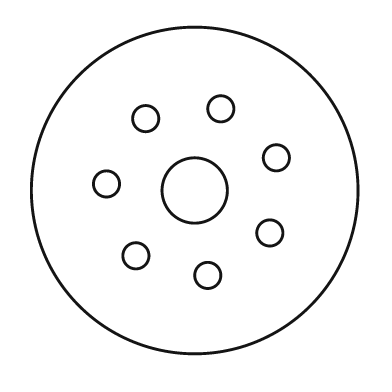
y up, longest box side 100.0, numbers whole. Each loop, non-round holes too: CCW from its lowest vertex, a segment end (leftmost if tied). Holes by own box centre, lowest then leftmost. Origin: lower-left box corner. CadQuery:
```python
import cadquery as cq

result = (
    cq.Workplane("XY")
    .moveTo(50.0, 50.0)
    .circle(50.0)
    .moveTo(54.0, 24.0)
    .circle(4.0)
    .moveTo(32.0, 30.0)
    .circle(4.0)
    .moveTo(73.0, 37.0)
    .circle(4.0)
    .moveTo(50.0, 50.0)
    .circle(10.0)
    .moveTo(23.0, 52.0)
    .circle(4.0)
    .moveTo(75.0, 60.0)
    .circle(4.0)
    .moveTo(35.0, 72.0)
    .circle(4.0)
    .moveTo(58.0, 75.0)
    .circle(4.0)
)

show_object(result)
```